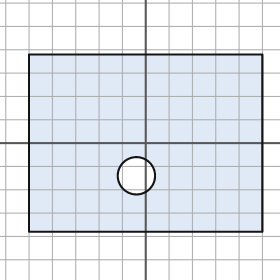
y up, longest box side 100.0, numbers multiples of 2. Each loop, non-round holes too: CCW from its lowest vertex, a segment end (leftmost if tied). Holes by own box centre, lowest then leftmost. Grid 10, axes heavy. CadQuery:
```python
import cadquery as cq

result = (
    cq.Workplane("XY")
    .moveTo(-50.0, -38.0)
    .lineTo(50.0, -38.0)
    .lineTo(50.0, 38.0)
    .lineTo(-50.0, 38.0)
    .close()
    .moveTo(-4.0, -14.0)
    .circle(8.0)
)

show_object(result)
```